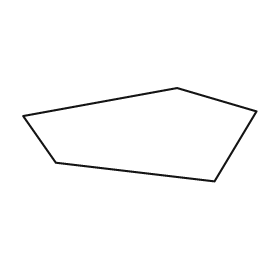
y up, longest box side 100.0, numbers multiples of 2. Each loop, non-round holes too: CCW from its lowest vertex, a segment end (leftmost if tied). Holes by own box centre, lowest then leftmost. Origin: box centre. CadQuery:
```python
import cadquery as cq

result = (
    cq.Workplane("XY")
    .moveTo(32.0, -20.0)
    .lineTo(50.0, 10.0)
    .lineTo(16.0, 20.0)
    .lineTo(-50.0, 8.0)
    .lineTo(-36.0, -12.0)
    .close()
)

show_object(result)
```